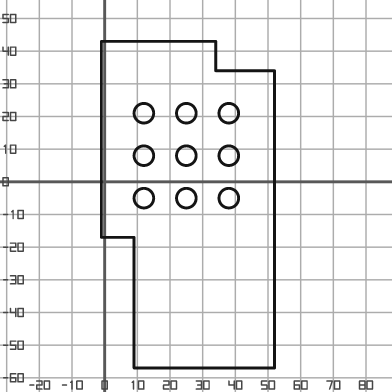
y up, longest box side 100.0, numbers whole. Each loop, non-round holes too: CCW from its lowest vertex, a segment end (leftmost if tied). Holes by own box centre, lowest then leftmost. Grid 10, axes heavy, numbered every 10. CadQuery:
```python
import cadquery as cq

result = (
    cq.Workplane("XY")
    .moveTo(9.0, -57.0)
    .lineTo(52.0, -57.0)
    .lineTo(52.0, 34.0)
    .lineTo(34.0, 34.0)
    .lineTo(34.0, 43.0)
    .lineTo(-1.0, 43.0)
    .lineTo(-1.0, -17.0)
    .lineTo(9.0, -17.0)
    .close()
    .moveTo(12.0, -5.0)
    .circle(3.0)
    .moveTo(25.0, -5.0)
    .circle(3.0)
    .moveTo(38.0, -5.0)
    .circle(3.0)
    .moveTo(12.0, 8.0)
    .circle(3.0)
    .moveTo(25.0, 8.0)
    .circle(3.0)
    .moveTo(38.0, 8.0)
    .circle(3.0)
    .moveTo(12.0, 21.0)
    .circle(3.0)
    .moveTo(25.0, 21.0)
    .circle(3.0)
    .moveTo(38.0, 21.0)
    .circle(3.0)
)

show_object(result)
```